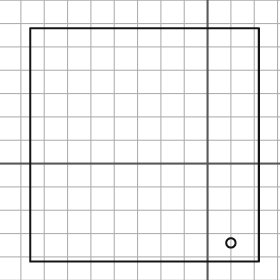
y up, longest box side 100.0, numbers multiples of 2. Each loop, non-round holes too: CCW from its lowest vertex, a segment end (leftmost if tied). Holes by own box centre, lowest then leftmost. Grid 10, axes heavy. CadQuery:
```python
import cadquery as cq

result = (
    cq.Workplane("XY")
    .moveTo(-76.0, -42.0)
    .lineTo(22.0, -42.0)
    .lineTo(22.0, 58.0)
    .lineTo(-76.0, 58.0)
    .close()
    .moveTo(10.0, -34.0)
    .circle(2.0)
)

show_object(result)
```